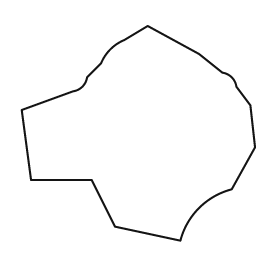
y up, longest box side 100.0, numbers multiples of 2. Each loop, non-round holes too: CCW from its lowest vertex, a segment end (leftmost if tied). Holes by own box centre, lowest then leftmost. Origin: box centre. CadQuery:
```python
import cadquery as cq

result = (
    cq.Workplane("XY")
    .moveTo(18.0, -46.0)
    .threePointArc((26.0, -32.0), (40.0, -24.0))
    .lineTo(50.0, -6.0)
    .lineTo(48.0, 12.0)
    .lineTo(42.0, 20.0)
    .threePointArc((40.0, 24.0), (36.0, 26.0))
    .lineTo(26.0, 34.0)
    .lineTo(4.0, 46.0)
    .lineTo(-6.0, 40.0)
    .threePointArc((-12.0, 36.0), (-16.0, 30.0))
    .lineTo(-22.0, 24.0)
    .threePointArc((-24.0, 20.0), (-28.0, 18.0))
    .lineTo(-50.0, 10.0)
    .lineTo(-46.0, -20.0)
    .lineTo(-20.0, -20.0)
    .lineTo(-10.0, -40.0)
    .close()
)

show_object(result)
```